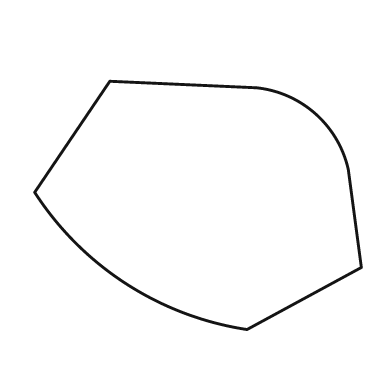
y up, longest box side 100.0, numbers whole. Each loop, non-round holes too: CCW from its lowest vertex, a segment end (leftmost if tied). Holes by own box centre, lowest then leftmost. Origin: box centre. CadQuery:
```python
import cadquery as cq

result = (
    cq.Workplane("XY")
    .moveTo(15.0, -38.0)
    .lineTo(50.0, -19.0)
    .lineTo(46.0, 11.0)
    .threePointArc((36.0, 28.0), (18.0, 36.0))
    .lineTo(-27.0, 38.0)
    .lineTo(-50.0, 4.0)
    .threePointArc((-22.0, -24.0), (15.0, -38.0))
    .close()
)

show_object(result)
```